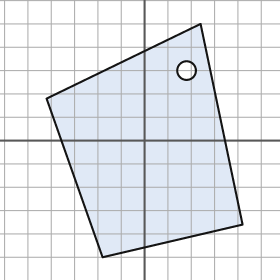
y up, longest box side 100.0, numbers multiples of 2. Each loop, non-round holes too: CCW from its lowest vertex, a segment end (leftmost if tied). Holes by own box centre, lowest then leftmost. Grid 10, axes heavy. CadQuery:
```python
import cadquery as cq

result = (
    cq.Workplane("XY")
    .moveTo(-18.0, -50.0)
    .lineTo(42.0, -36.0)
    .lineTo(24.0, 50.0)
    .lineTo(-42.0, 18.0)
    .close()
    .moveTo(18.0, 30.0)
    .circle(4.0)
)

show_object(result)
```